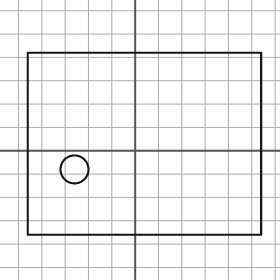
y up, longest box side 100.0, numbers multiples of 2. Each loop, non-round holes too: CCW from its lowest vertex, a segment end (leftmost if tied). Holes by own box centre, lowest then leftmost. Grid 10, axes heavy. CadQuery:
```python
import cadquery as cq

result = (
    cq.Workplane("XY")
    .moveTo(-46.0, -36.0)
    .lineTo(54.0, -36.0)
    .lineTo(54.0, 42.0)
    .lineTo(-46.0, 42.0)
    .close()
    .moveTo(-26.0, -8.0)
    .circle(6.0)
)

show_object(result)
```